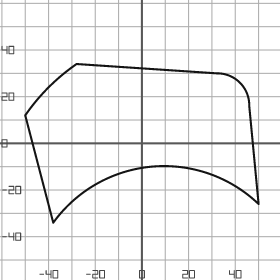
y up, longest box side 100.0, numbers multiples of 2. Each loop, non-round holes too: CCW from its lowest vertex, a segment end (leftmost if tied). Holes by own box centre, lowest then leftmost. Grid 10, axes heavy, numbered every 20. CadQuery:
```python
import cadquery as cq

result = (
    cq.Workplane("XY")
    .moveTo(-38.0, -34.0)
    .threePointArc((4.0, -10.0), (50.0, -26.0))
    .lineTo(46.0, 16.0)
    .threePointArc((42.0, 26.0), (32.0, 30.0))
    .lineTo(-28.0, 34.0)
    .threePointArc((-40.0, 24.0), (-50.0, 12.0))
    .close()
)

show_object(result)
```